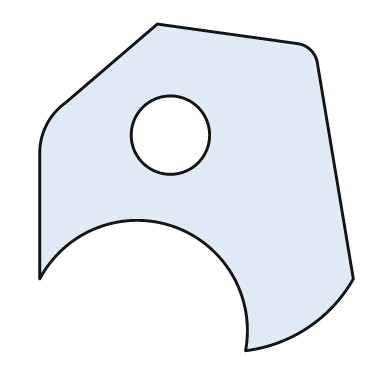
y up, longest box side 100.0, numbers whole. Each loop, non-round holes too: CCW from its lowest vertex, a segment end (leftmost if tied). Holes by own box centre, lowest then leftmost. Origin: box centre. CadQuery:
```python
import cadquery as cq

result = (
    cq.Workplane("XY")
    .moveTo(15.0, -50.0)
    .threePointArc((34.0, -43.0), (48.0, -28.0))
    .lineTo(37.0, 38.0)
    .threePointArc((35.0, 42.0), (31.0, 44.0))
    .lineTo(-12.0, 50.0)
    .lineTo(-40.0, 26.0)
    .threePointArc((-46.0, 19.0), (-48.0, 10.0))
    .lineTo(-48.0, -28.0)
    .threePointArc((-7.0, -12.0), (15.0, -50.0))
    .close()
    .moveTo(-8.0, 16.0)
    .circle(12.0)
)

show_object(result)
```